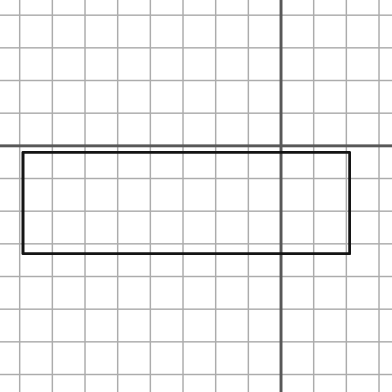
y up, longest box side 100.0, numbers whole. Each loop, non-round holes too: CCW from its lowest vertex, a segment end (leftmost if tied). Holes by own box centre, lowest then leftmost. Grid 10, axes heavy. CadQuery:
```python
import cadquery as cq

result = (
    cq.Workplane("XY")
    .moveTo(-79.0, -33.0)
    .lineTo(21.0, -33.0)
    .lineTo(21.0, -2.0)
    .lineTo(-79.0, -2.0)
    .close()
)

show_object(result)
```